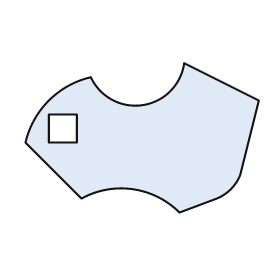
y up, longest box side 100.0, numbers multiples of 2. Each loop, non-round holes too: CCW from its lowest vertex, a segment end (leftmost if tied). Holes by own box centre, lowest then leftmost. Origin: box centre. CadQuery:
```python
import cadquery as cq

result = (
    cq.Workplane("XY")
    .moveTo(16.0, -32.0)
    .lineTo(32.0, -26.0)
    .threePointArc((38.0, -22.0), (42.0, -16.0))
    .lineTo(50.0, 16.0)
    .lineTo(18.0, 32.0)
    .threePointArc((0.0, 14.0), (-22.0, 26.0))
    .threePointArc((-40.0, 16.0), (-50.0, -2.0))
    .lineTo(-26.0, -26.0)
    .threePointArc((-4.0, -22.0), (16.0, -32.0))
    .close()
    .moveTo(-40.0, -2.0)
    .lineTo(-28.0, -2.0)
    .lineTo(-28.0, 10.0)
    .lineTo(-40.0, 10.0)
    .close()
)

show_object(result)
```